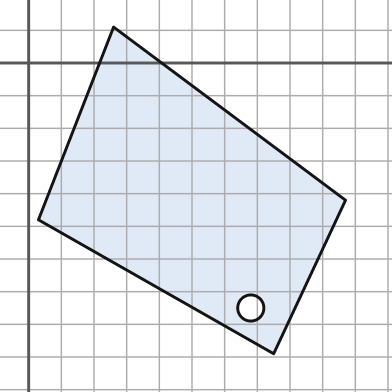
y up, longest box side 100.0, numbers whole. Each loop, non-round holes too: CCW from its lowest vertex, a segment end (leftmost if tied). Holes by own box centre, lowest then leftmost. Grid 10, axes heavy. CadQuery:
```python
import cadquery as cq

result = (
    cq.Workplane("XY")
    .moveTo(75.0, -89.0)
    .lineTo(97.0, -42.0)
    .lineTo(26.0, 11.0)
    .lineTo(3.0, -48.0)
    .close()
    .moveTo(68.0, -75.0)
    .circle(4.0)
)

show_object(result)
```